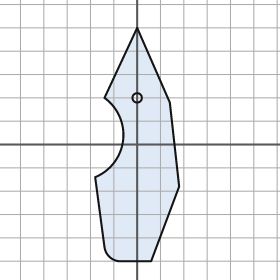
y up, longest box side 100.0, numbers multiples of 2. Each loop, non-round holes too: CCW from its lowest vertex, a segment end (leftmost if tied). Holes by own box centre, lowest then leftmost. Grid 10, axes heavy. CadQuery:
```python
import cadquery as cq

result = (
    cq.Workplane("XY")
    .moveTo(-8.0, -50.0)
    .lineTo(6.0, -50.0)
    .lineTo(18.0, -18.0)
    .lineTo(14.0, 18.0)
    .lineTo(0.0, 50.0)
    .lineTo(-14.0, 20.0)
    .threePointArc((-6.0, 2.0), (-18.0, -14.0))
    .lineTo(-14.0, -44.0)
    .threePointArc((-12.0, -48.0), (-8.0, -50.0))
    .close()
    .moveTo(0.0, 20.0)
    .circle(2.0)
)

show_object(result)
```